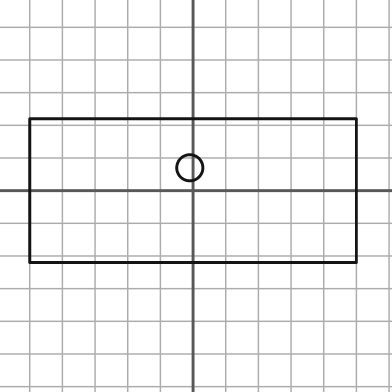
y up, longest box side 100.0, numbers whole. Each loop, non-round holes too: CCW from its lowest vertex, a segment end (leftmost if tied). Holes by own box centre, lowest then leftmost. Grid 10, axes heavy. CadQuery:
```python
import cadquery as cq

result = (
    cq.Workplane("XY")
    .moveTo(-50.0, -22.0)
    .lineTo(50.0, -22.0)
    .lineTo(50.0, 22.0)
    .lineTo(-50.0, 22.0)
    .close()
    .moveTo(-1.0, 7.0)
    .circle(4.0)
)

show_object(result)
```